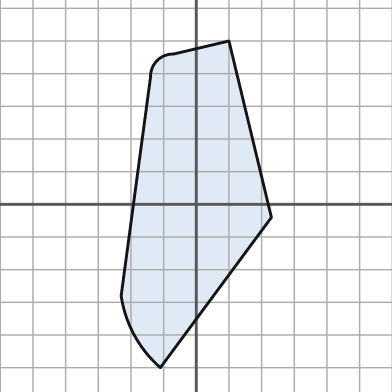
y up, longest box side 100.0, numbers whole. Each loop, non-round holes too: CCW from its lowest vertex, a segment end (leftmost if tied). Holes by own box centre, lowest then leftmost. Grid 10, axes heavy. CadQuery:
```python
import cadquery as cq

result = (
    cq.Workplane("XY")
    .moveTo(-11.0, -50.0)
    .lineTo(23.0, -4.0)
    .lineTo(10.0, 50.0)
    .lineTo(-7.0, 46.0)
    .threePointArc((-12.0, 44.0), (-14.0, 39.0))
    .lineTo(-23.0, -28.0)
    .threePointArc((-19.0, -40.0), (-11.0, -50.0))
    .close()
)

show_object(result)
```